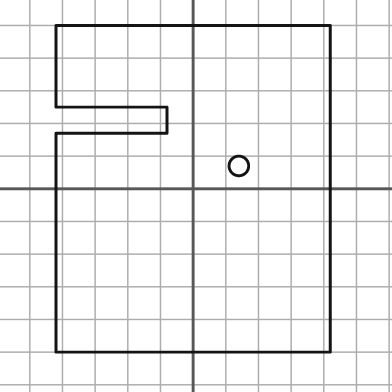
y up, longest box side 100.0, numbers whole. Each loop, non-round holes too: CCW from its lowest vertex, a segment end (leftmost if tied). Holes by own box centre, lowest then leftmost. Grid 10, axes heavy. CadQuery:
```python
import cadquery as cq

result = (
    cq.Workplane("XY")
    .moveTo(-42.0, -50.0)
    .lineTo(42.0, -50.0)
    .lineTo(42.0, 50.0)
    .lineTo(-42.0, 50.0)
    .lineTo(-42.0, 25.0)
    .lineTo(-8.0, 25.0)
    .lineTo(-8.0, 17.0)
    .lineTo(-42.0, 17.0)
    .close()
    .moveTo(14.0, 7.0)
    .circle(3.0)
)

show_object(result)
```